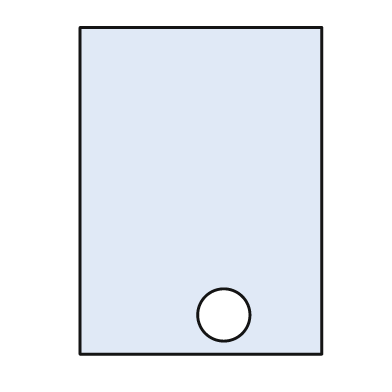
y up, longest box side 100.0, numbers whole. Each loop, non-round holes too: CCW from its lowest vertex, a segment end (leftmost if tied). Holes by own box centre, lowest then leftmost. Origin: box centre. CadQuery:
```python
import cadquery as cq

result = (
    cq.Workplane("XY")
    .moveTo(-37.0, -50.0)
    .lineTo(37.0, -50.0)
    .lineTo(37.0, 50.0)
    .lineTo(-37.0, 50.0)
    .close()
    .moveTo(7.0, -38.0)
    .circle(8.0)
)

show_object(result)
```